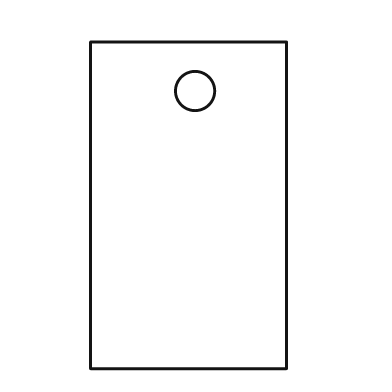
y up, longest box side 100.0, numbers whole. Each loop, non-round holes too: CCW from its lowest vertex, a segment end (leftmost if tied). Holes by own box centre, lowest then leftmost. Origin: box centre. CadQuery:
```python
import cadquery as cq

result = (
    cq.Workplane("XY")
    .moveTo(-30.0, -50.0)
    .lineTo(30.0, -50.0)
    .lineTo(30.0, 50.0)
    .lineTo(-30.0, 50.0)
    .close()
    .moveTo(2.0, 35.0)
    .circle(6.0)
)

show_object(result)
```